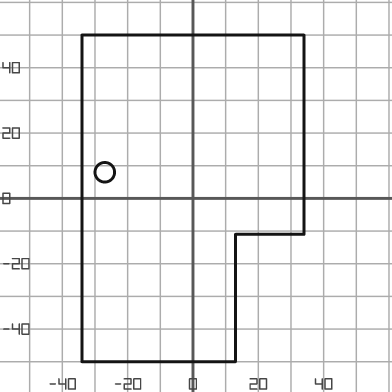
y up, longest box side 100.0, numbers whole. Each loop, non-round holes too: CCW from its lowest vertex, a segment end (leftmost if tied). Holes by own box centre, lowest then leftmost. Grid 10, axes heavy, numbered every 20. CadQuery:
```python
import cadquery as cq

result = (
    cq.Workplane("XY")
    .moveTo(-34.0, -50.0)
    .lineTo(13.0, -50.0)
    .lineTo(13.0, -11.0)
    .lineTo(34.0, -11.0)
    .lineTo(34.0, 50.0)
    .lineTo(-34.0, 50.0)
    .close()
    .moveTo(-27.0, 8.0)
    .circle(3.0)
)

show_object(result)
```